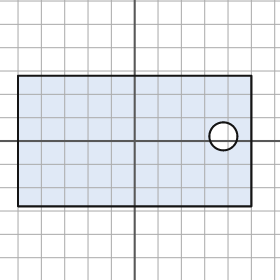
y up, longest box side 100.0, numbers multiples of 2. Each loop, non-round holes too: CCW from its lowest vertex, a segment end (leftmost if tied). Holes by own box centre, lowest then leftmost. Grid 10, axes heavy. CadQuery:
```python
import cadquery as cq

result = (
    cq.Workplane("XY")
    .moveTo(-50.0, -28.0)
    .lineTo(50.0, -28.0)
    .lineTo(50.0, 28.0)
    .lineTo(-50.0, 28.0)
    .close()
    .moveTo(38.0, 2.0)
    .circle(6.0)
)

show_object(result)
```